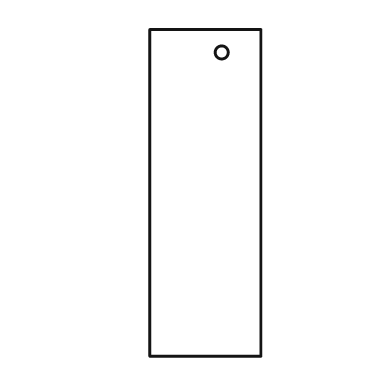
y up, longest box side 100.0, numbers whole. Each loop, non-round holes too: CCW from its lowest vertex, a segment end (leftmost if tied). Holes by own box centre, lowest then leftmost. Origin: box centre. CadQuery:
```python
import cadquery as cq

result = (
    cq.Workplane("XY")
    .moveTo(-17.0, -50.0)
    .lineTo(17.0, -50.0)
    .lineTo(17.0, 50.0)
    .lineTo(-17.0, 50.0)
    .close()
    .moveTo(5.0, 43.0)
    .circle(2.0)
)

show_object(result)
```